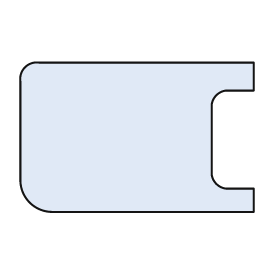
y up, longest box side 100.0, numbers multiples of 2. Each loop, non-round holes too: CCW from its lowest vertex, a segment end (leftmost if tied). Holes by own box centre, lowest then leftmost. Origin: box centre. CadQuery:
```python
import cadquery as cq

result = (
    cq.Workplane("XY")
    .moveTo(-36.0, -32.0)
    .lineTo(50.0, -32.0)
    .lineTo(50.0, -22.0)
    .lineTo(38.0, -22.0)
    .threePointArc((34.0, -20.0), (32.0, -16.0))
    .lineTo(32.0, 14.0)
    .threePointArc((34.0, 18.0), (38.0, 20.0))
    .lineTo(50.0, 20.0)
    .lineTo(50.0, 32.0)
    .lineTo(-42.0, 32.0)
    .threePointArc((-48.0, 30.0), (-50.0, 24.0))
    .lineTo(-50.0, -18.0)
    .threePointArc((-46.0, -28.0), (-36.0, -32.0))
    .close()
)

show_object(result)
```